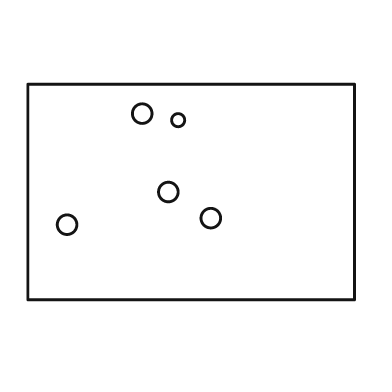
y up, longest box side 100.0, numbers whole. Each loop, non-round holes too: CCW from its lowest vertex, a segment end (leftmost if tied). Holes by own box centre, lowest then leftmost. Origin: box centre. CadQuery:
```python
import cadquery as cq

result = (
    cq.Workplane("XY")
    .moveTo(-50.0, -33.0)
    .lineTo(50.0, -33.0)
    .lineTo(50.0, 33.0)
    .lineTo(-50.0, 33.0)
    .close()
    .moveTo(-38.0, -10.0)
    .circle(3.0)
    .moveTo(6.0, -8.0)
    .circle(3.0)
    .moveTo(-7.0, 0.0)
    .circle(3.0)
    .moveTo(-4.0, 22.0)
    .circle(2.0)
    .moveTo(-15.0, 24.0)
    .circle(3.0)
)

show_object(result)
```